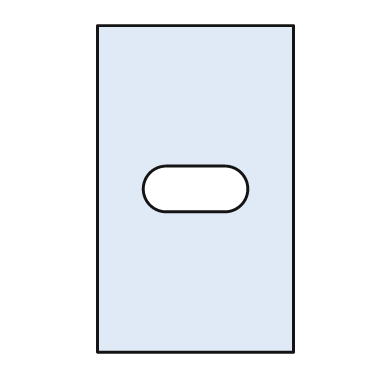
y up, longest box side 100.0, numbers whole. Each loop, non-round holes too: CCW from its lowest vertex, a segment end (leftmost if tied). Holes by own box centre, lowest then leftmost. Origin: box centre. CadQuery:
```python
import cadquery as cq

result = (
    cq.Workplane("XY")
    .moveTo(-30.0, -50.0)
    .lineTo(30.0, -50.0)
    .lineTo(30.0, 50.0)
    .lineTo(-30.0, 50.0)
    .close()
    .moveTo(-9.0, -7.0)
    .lineTo(9.0, -7.0)
    .threePointArc((16.0, 0.0), (9.0, 7.0))
    .lineTo(-9.0, 7.0)
    .threePointArc((-16.0, 0.0), (-9.0, -7.0))
    .close()
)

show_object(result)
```